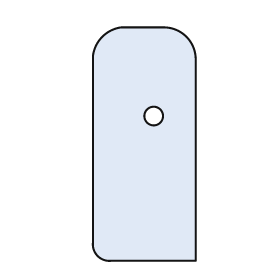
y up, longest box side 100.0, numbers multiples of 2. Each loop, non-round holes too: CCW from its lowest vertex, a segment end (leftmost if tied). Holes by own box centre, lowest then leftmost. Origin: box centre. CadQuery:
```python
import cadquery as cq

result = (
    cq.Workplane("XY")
    .moveTo(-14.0, -50.0)
    .lineTo(22.0, -50.0)
    .lineTo(22.0, 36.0)
    .threePointArc((18.0, 46.0), (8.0, 50.0))
    .lineTo(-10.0, 50.0)
    .threePointArc((-18.0, 46.0), (-22.0, 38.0))
    .lineTo(-22.0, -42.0)
    .threePointArc((-20.0, -48.0), (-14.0, -50.0))
    .close()
    .moveTo(4.0, 12.0)
    .circle(4.0)
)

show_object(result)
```